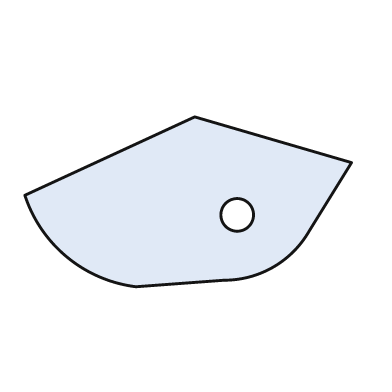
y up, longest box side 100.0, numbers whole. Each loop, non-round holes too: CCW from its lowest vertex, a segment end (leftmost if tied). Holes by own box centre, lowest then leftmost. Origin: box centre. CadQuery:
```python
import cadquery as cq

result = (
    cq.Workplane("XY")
    .moveTo(-16.0, -26.0)
    .lineTo(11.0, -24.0)
    .threePointArc((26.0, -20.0), (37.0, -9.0))
    .lineTo(50.0, 12.0)
    .lineTo(2.0, 26.0)
    .lineTo(-50.0, 2.0)
    .threePointArc((-37.0, -17.0), (-16.0, -26.0))
    .close()
    .moveTo(15.0, -4.0)
    .circle(5.0)
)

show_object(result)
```